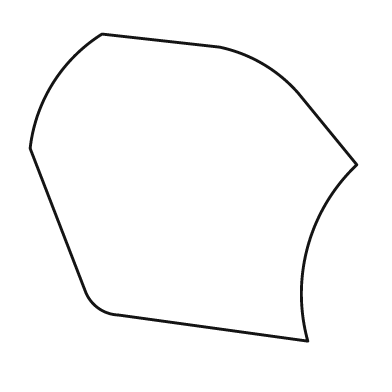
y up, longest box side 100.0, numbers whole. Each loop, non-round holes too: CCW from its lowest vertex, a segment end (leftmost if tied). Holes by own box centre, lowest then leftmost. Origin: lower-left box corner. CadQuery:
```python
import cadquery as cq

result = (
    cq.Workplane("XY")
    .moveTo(85.0, 0.0)
    .threePointArc((85.0, 29.0), (100.0, 54.0))
    .lineTo(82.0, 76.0)
    .threePointArc((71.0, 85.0), (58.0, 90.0))
    .lineTo(22.0, 94.0)
    .threePointArc((7.0, 79.0), (0.0, 59.0))
    .lineTo(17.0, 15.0)
    .threePointArc((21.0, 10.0), (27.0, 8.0))
    .close()
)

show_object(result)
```